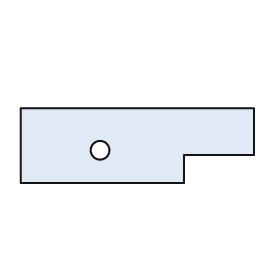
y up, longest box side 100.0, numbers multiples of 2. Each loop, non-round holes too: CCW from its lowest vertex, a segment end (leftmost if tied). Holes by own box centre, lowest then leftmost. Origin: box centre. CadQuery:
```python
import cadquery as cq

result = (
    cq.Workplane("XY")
    .moveTo(-50.0, -16.0)
    .lineTo(20.0, -16.0)
    .lineTo(20.0, -4.0)
    .lineTo(50.0, -4.0)
    .lineTo(50.0, 16.0)
    .lineTo(-50.0, 16.0)
    .close()
    .moveTo(-16.0, -2.0)
    .circle(4.0)
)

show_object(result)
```